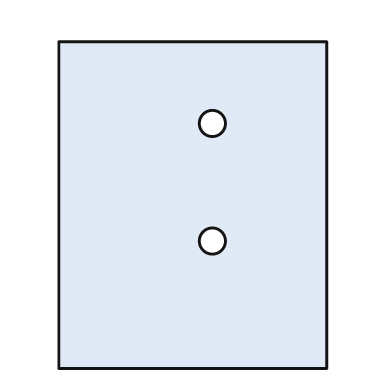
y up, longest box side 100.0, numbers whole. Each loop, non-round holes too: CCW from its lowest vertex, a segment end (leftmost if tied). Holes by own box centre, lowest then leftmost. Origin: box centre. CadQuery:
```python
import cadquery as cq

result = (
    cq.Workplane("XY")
    .moveTo(-41.0, -50.0)
    .lineTo(41.0, -50.0)
    .lineTo(41.0, 50.0)
    .lineTo(-41.0, 50.0)
    .close()
    .moveTo(6.0, -11.0)
    .circle(4.0)
    .moveTo(6.0, 25.0)
    .circle(4.0)
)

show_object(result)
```